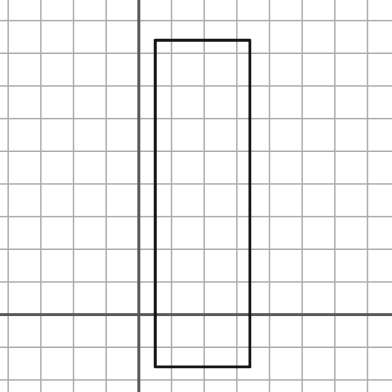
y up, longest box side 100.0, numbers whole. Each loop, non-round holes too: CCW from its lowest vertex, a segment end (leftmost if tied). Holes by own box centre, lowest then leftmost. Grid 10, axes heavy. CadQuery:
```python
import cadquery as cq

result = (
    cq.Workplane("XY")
    .moveTo(5.0, -16.0)
    .lineTo(34.0, -16.0)
    .lineTo(34.0, 84.0)
    .lineTo(5.0, 84.0)
    .close()
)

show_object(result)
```